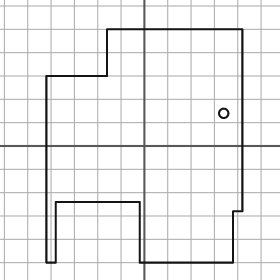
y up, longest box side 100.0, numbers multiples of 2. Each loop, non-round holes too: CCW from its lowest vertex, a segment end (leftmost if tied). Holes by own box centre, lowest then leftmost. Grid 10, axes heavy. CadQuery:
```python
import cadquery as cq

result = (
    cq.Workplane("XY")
    .moveTo(-42.0, -50.0)
    .lineTo(-38.0, -50.0)
    .lineTo(-38.0, -24.0)
    .lineTo(-2.0, -24.0)
    .lineTo(-2.0, -50.0)
    .lineTo(38.0, -50.0)
    .lineTo(38.0, -28.0)
    .lineTo(42.0, -28.0)
    .lineTo(42.0, 50.0)
    .lineTo(-16.0, 50.0)
    .lineTo(-16.0, 30.0)
    .lineTo(-42.0, 30.0)
    .close()
    .moveTo(34.0, 14.0)
    .circle(2.0)
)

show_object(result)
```